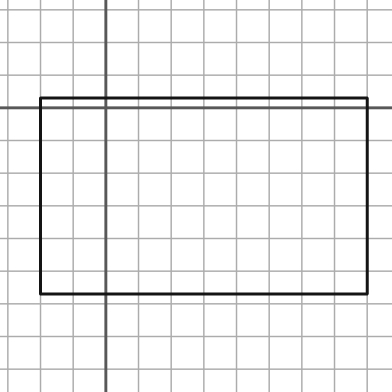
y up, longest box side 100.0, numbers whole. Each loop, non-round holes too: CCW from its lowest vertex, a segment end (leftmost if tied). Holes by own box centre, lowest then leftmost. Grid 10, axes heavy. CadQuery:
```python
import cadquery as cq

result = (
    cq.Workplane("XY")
    .moveTo(-20.0, -57.0)
    .lineTo(80.0, -57.0)
    .lineTo(80.0, 3.0)
    .lineTo(-20.0, 3.0)
    .close()
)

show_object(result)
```